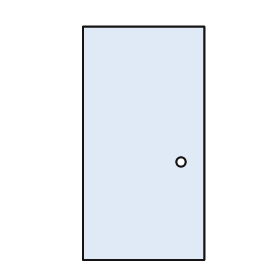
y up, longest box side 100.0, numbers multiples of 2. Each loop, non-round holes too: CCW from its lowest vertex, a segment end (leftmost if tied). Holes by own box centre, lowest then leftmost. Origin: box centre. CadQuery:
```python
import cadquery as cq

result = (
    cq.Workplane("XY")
    .moveTo(-26.0, -50.0)
    .lineTo(26.0, -50.0)
    .lineTo(26.0, 50.0)
    .lineTo(-26.0, 50.0)
    .close()
    .moveTo(16.0, -8.0)
    .circle(2.0)
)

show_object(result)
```